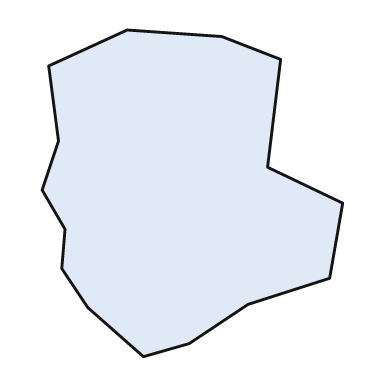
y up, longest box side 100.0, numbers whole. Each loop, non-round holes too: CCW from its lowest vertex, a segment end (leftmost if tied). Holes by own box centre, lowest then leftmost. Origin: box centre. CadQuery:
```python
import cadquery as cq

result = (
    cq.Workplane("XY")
    .moveTo(-15.0, -50.0)
    .lineTo(-1.0, -46.0)
    .lineTo(17.0, -34.0)
    .lineTo(42.0, -26.0)
    .lineTo(46.0, -3.0)
    .lineTo(23.0, 8.0)
    .lineTo(27.0, 41.0)
    .lineTo(9.0, 48.0)
    .lineTo(-20.0, 50.0)
    .lineTo(-44.0, 39.0)
    .lineTo(-41.0, 16.0)
    .lineTo(-46.0, 1.0)
    .lineTo(-39.0, -11.0)
    .lineTo(-40.0, -23.0)
    .lineTo(-32.0, -35.0)
    .close()
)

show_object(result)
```